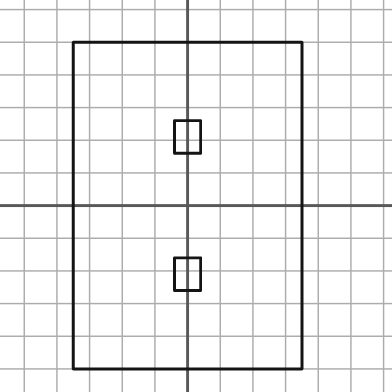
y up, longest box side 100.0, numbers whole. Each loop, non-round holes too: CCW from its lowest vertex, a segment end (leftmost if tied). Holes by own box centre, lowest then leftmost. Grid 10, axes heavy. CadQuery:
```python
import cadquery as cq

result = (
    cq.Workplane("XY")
    .moveTo(-35.0, -50.0)
    .lineTo(35.0, -50.0)
    .lineTo(35.0, 50.0)
    .lineTo(-35.0, 50.0)
    .close()
    .moveTo(-4.0, -26.0)
    .lineTo(4.0, -26.0)
    .lineTo(4.0, -16.0)
    .lineTo(-4.0, -16.0)
    .close()
    .moveTo(-4.0, 16.0)
    .lineTo(4.0, 16.0)
    .lineTo(4.0, 26.0)
    .lineTo(-4.0, 26.0)
    .close()
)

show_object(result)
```